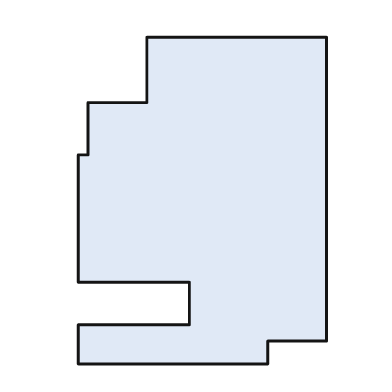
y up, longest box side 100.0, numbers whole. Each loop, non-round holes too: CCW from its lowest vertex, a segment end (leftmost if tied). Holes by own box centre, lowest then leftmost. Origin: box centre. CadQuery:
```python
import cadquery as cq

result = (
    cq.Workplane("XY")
    .moveTo(-38.0, -50.0)
    .lineTo(20.0, -50.0)
    .lineTo(20.0, -43.0)
    .lineTo(38.0, -43.0)
    .lineTo(38.0, 50.0)
    .lineTo(-17.0, 50.0)
    .lineTo(-17.0, 30.0)
    .lineTo(-35.0, 30.0)
    .lineTo(-35.0, 14.0)
    .lineTo(-38.0, 14.0)
    .lineTo(-38.0, -25.0)
    .lineTo(-4.0, -25.0)
    .lineTo(-4.0, -38.0)
    .lineTo(-38.0, -38.0)
    .close()
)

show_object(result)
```